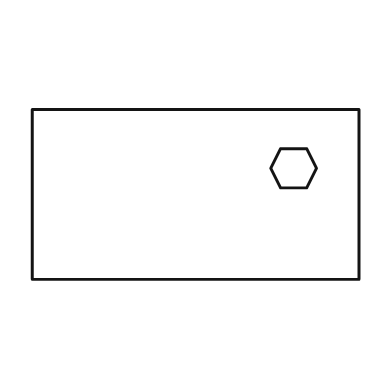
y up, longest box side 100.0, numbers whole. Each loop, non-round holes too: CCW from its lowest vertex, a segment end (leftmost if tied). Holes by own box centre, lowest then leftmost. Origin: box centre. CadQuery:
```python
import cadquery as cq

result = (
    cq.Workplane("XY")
    .moveTo(-50.0, -26.0)
    .lineTo(50.0, -26.0)
    .lineTo(50.0, 26.0)
    .lineTo(-50.0, 26.0)
    .close()
    .moveTo(26.0, 2.0)
    .lineTo(34.0, 2.0)
    .lineTo(37.0, 8.0)
    .lineTo(34.0, 14.0)
    .lineTo(26.0, 14.0)
    .lineTo(23.0, 8.0)
    .close()
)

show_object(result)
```